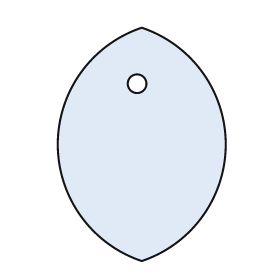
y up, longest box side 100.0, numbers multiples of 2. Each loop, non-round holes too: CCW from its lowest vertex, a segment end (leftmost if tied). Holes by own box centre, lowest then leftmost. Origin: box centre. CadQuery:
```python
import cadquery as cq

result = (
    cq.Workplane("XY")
    .moveTo(0.0, -50.0)
    .threePointArc((36.0, 0.0), (0.0, 50.0))
    .threePointArc((-36.0, 0.0), (0.0, -50.0))
    .close()
    .moveTo(-2.0, 26.0)
    .circle(4.0)
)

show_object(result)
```